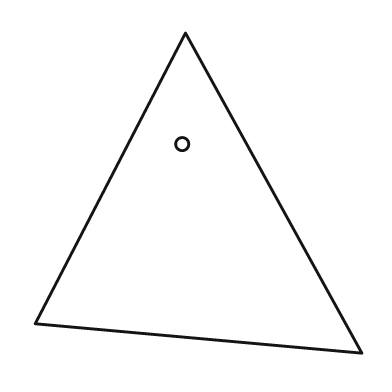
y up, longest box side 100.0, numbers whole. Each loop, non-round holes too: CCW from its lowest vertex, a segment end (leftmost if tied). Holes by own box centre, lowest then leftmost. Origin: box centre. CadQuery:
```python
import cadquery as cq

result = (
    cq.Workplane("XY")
    .moveTo(50.0, -49.0)
    .lineTo(-4.0, 49.0)
    .lineTo(-50.0, -40.0)
    .close()
    .moveTo(-5.0, 15.0)
    .circle(2.0)
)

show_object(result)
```